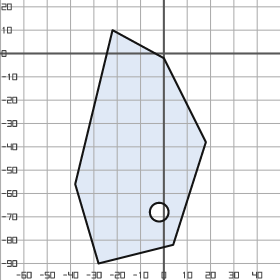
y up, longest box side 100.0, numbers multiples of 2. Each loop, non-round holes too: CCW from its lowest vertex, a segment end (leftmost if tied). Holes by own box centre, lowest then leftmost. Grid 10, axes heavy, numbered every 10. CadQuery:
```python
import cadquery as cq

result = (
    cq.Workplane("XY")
    .moveTo(-28.0, -90.0)
    .lineTo(4.0, -82.0)
    .lineTo(18.0, -38.0)
    .lineTo(0.0, -2.0)
    .lineTo(-22.0, 10.0)
    .lineTo(-38.0, -56.0)
    .close()
    .moveTo(-2.0, -68.0)
    .circle(4.0)
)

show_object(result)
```